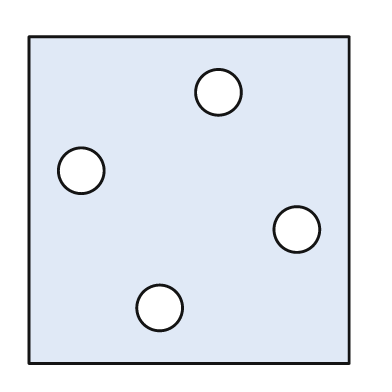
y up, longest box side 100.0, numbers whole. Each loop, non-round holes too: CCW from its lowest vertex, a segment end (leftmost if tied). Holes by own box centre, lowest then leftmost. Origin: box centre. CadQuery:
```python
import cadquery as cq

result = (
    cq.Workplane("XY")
    .moveTo(-49.0, -50.0)
    .lineTo(49.0, -50.0)
    .lineTo(49.0, 50.0)
    .lineTo(-49.0, 50.0)
    .close()
    .moveTo(-9.0, -33.0)
    .circle(7.0)
    .moveTo(33.0, -9.0)
    .circle(7.0)
    .moveTo(-33.0, 9.0)
    .circle(7.0)
    .moveTo(9.0, 33.0)
    .circle(7.0)
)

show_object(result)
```